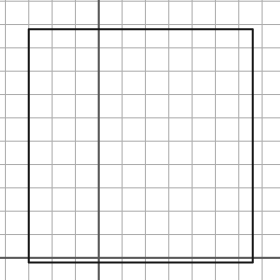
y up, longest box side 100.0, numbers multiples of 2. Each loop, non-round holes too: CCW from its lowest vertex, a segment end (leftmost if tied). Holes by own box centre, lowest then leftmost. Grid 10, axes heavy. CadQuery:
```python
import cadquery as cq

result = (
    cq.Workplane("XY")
    .moveTo(-30.0, -2.0)
    .lineTo(66.0, -2.0)
    .lineTo(66.0, 98.0)
    .lineTo(-30.0, 98.0)
    .close()
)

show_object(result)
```